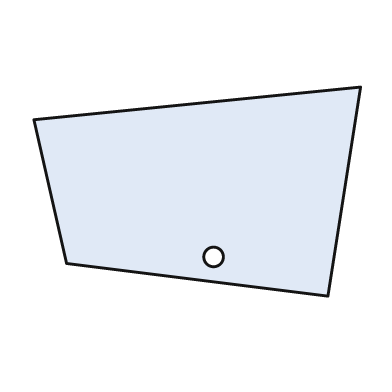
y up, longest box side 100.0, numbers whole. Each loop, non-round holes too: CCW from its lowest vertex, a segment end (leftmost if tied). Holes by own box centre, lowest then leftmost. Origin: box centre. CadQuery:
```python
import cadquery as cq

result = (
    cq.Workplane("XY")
    .moveTo(40.0, -32.0)
    .lineTo(50.0, 32.0)
    .lineTo(-50.0, 22.0)
    .lineTo(-40.0, -22.0)
    .close()
    .moveTo(5.0, -20.0)
    .circle(3.0)
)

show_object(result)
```